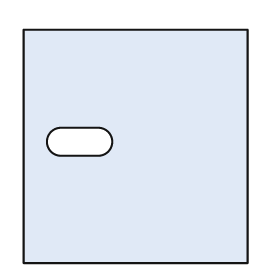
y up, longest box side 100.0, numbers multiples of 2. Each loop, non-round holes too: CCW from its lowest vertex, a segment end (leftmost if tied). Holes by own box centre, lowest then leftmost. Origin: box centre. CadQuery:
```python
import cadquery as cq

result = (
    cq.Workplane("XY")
    .moveTo(-48.0, -50.0)
    .lineTo(48.0, -50.0)
    .lineTo(48.0, 50.0)
    .lineTo(-48.0, 50.0)
    .close()
    .moveTo(-32.0, -4.0)
    .lineTo(-16.0, -4.0)
    .threePointArc((-10.0, 2.0), (-16.0, 8.0))
    .lineTo(-32.0, 8.0)
    .threePointArc((-38.0, 2.0), (-32.0, -4.0))
    .close()
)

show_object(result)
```